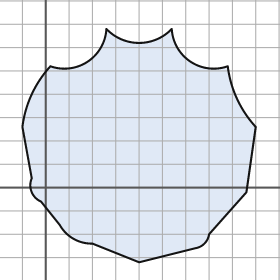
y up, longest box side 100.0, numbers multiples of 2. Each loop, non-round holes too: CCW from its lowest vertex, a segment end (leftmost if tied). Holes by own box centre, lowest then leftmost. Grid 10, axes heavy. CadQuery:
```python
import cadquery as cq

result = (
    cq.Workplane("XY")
    .moveTo(40.0, -32.0)
    .lineTo(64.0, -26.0)
    .threePointArc((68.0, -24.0), (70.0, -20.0))
    .lineTo(86.0, -2.0)
    .lineTo(90.0, 26.0)
    .threePointArc((82.0, 38.0), (78.0, 52.0))
    .threePointArc((62.0, 54.0), (54.0, 68.0))
    .threePointArc((40.0, 62.0), (26.0, 68.0))
    .threePointArc((18.0, 54.0), (2.0, 52.0))
    .threePointArc((-6.0, 40.0), (-10.0, 26.0))
    .lineTo(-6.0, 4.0)
    .threePointArc((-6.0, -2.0), (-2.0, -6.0))
    .lineTo(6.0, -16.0)
    .threePointArc((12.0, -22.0), (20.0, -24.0))
    .close()
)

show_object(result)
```